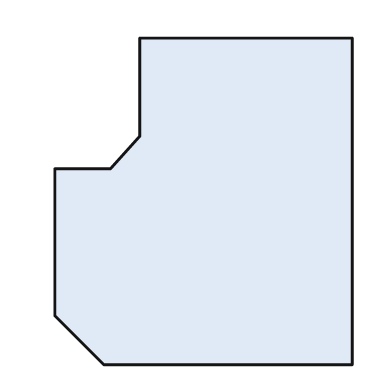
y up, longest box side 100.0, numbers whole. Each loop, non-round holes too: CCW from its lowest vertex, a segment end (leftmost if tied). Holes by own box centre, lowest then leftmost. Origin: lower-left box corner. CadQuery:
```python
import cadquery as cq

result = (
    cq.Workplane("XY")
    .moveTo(15.0, 0.0)
    .lineTo(91.0, 0.0)
    .lineTo(91.0, 100.0)
    .lineTo(26.0, 100.0)
    .lineTo(26.0, 70.0)
    .lineTo(17.0, 60.0)
    .lineTo(0.0, 60.0)
    .lineTo(0.0, 15.0)
    .close()
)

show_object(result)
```